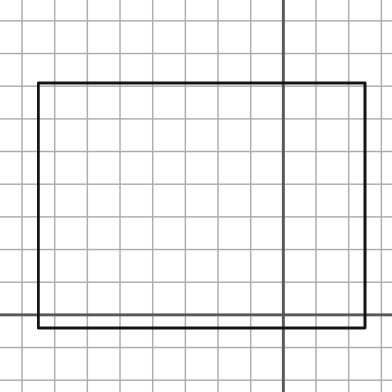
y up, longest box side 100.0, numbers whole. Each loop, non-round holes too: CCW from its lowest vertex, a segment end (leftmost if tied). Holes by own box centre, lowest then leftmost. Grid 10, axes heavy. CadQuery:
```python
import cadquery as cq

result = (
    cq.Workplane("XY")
    .moveTo(-75.0, -4.0)
    .lineTo(25.0, -4.0)
    .lineTo(25.0, 71.0)
    .lineTo(-75.0, 71.0)
    .close()
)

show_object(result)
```